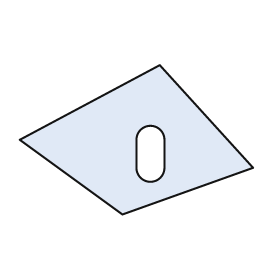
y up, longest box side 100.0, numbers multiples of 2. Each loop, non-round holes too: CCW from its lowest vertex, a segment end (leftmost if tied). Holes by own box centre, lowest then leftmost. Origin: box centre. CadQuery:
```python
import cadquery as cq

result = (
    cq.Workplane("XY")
    .moveTo(-6.0, -32.0)
    .lineTo(50.0, -12.0)
    .lineTo(10.0, 32.0)
    .lineTo(-50.0, 0.0)
    .close()
    .moveTo(0.0, -12.0)
    .threePointArc((6.0, -18.0), (12.0, -12.0))
    .lineTo(12.0, 0.0)
    .threePointArc((6.0, 6.0), (0.0, 0.0))
    .close()
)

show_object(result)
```